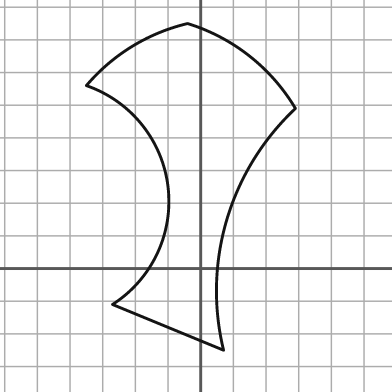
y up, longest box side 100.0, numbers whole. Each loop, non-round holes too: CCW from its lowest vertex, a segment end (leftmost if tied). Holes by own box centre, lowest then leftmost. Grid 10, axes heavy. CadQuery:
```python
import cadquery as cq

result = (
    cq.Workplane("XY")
    .moveTo(7.0, -25.0)
    .threePointArc((8.0, 15.0), (29.0, 49.0))
    .threePointArc((15.0, 65.0), (-4.0, 75.0))
    .threePointArc((-21.0, 68.0), (-35.0, 56.0))
    .threePointArc((-10.0, 25.0), (-27.0, -11.0))
    .close()
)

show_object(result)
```